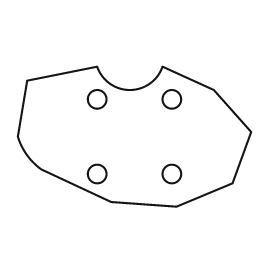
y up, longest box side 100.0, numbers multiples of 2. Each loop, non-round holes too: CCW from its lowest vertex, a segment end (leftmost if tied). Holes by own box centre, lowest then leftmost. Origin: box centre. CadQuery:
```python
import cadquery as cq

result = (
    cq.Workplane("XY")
    .moveTo(18.0, -30.0)
    .lineTo(42.0, -20.0)
    .lineTo(50.0, 2.0)
    .lineTo(34.0, 20.0)
    .lineTo(12.0, 30.0)
    .threePointArc((-2.0, 20.0), (-16.0, 30.0))
    .lineTo(-46.0, 24.0)
    .lineTo(-50.0, 0.0)
    .threePointArc((-46.0, -8.0), (-40.0, -14.0))
    .lineTo(-10.0, -28.0)
    .close()
    .moveTo(-16.0, -16.0)
    .circle(4.0)
    .moveTo(16.0, -16.0)
    .circle(4.0)
    .moveTo(-16.0, 16.0)
    .circle(4.0)
    .moveTo(16.0, 16.0)
    .circle(4.0)
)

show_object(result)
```